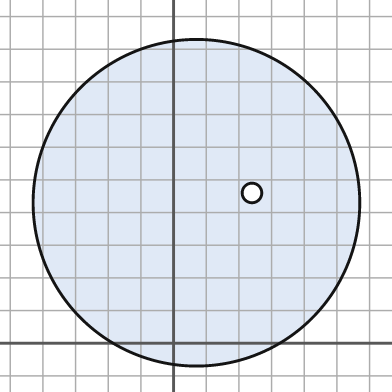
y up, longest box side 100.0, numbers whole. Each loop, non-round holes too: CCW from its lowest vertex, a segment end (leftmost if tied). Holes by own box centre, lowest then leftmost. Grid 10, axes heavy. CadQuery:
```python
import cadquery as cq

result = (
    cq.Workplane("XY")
    .moveTo(7.0, 43.0)
    .circle(50.0)
    .moveTo(24.0, 46.0)
    .circle(3.0)
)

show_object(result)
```